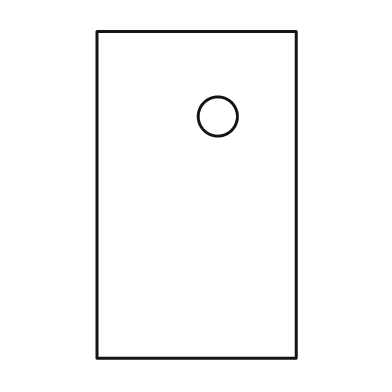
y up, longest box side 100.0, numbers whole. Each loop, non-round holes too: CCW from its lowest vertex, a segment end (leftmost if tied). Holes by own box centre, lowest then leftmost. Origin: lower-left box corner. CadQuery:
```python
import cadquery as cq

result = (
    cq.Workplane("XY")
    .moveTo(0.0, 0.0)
    .lineTo(61.0, 0.0)
    .lineTo(61.0, 100.0)
    .lineTo(0.0, 100.0)
    .close()
    .moveTo(37.0, 74.0)
    .circle(6.0)
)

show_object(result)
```